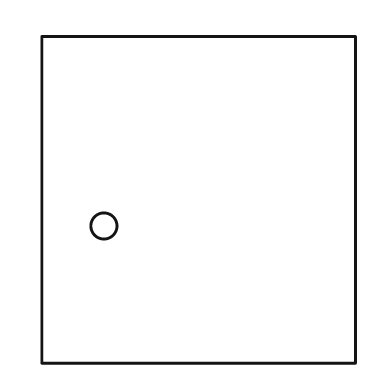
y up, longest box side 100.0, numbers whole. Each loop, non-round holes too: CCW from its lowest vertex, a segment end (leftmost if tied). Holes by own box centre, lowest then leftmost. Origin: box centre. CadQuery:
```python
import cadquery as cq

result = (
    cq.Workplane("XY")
    .moveTo(-48.0, -50.0)
    .lineTo(48.0, -50.0)
    .lineTo(48.0, 50.0)
    .lineTo(-48.0, 50.0)
    .close()
    .moveTo(-29.0, -8.0)
    .circle(4.0)
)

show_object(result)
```